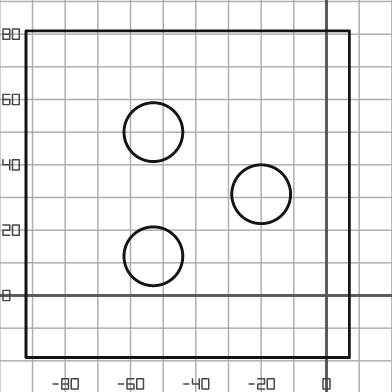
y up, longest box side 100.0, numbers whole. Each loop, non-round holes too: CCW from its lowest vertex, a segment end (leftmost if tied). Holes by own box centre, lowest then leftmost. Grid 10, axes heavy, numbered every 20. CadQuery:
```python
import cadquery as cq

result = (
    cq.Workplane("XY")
    .moveTo(-92.0, -19.0)
    .lineTo(7.0, -19.0)
    .lineTo(7.0, 81.0)
    .lineTo(-92.0, 81.0)
    .close()
    .moveTo(-53.0, 12.0)
    .circle(9.0)
    .moveTo(-20.0, 31.0)
    .circle(9.0)
    .moveTo(-53.0, 50.0)
    .circle(9.0)
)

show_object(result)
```